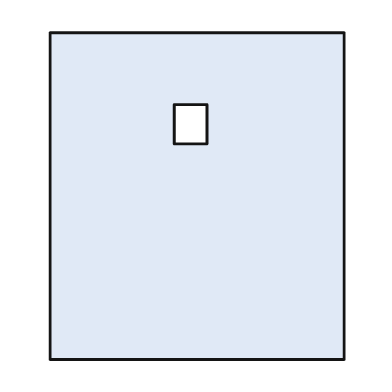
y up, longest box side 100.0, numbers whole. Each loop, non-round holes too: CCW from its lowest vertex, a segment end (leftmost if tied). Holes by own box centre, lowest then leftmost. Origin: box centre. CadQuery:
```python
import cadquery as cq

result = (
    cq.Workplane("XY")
    .moveTo(-45.0, -50.0)
    .lineTo(45.0, -50.0)
    .lineTo(45.0, 50.0)
    .lineTo(-45.0, 50.0)
    .close()
    .moveTo(-7.0, 16.0)
    .lineTo(3.0, 16.0)
    .lineTo(3.0, 28.0)
    .lineTo(-7.0, 28.0)
    .close()
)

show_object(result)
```